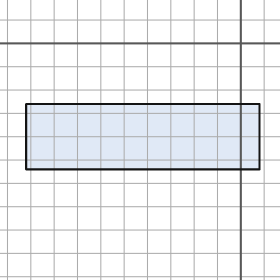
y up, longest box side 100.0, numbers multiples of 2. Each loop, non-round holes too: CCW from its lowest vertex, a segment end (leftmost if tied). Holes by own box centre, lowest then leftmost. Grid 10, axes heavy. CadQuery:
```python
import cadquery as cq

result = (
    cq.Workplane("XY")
    .moveTo(-92.0, -54.0)
    .lineTo(8.0, -54.0)
    .lineTo(8.0, -26.0)
    .lineTo(-92.0, -26.0)
    .close()
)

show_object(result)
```